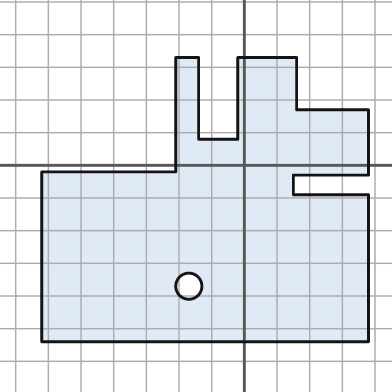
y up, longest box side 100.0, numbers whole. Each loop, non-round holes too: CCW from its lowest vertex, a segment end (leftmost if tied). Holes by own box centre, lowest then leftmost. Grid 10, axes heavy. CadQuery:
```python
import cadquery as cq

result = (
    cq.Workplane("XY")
    .moveTo(-62.0, -54.0)
    .lineTo(38.0, -54.0)
    .lineTo(38.0, -9.0)
    .lineTo(15.0, -9.0)
    .lineTo(15.0, -3.0)
    .lineTo(38.0, -3.0)
    .lineTo(38.0, 17.0)
    .lineTo(16.0, 17.0)
    .lineTo(16.0, 33.0)
    .lineTo(-2.0, 33.0)
    .lineTo(-2.0, 8.0)
    .lineTo(-14.0, 8.0)
    .lineTo(-14.0, 33.0)
    .lineTo(-21.0, 33.0)
    .lineTo(-21.0, -2.0)
    .lineTo(-62.0, -2.0)
    .close()
    .moveTo(-17.0, -37.0)
    .circle(4.0)
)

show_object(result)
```